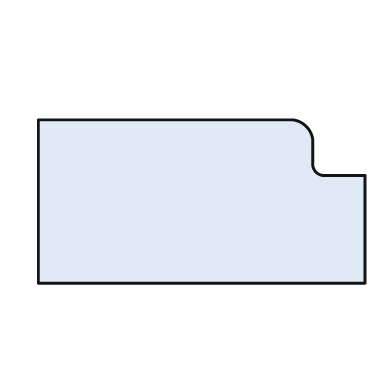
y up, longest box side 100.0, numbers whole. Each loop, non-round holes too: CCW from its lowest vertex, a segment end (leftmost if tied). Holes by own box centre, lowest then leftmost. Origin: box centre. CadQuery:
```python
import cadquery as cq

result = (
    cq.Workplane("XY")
    .moveTo(-50.0, -25.0)
    .lineTo(50.0, -25.0)
    .lineTo(50.0, 8.0)
    .lineTo(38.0, 8.0)
    .threePointArc((35.0, 9.0), (34.0, 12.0))
    .lineTo(34.0, 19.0)
    .threePointArc((32.0, 23.0), (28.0, 25.0))
    .lineTo(-50.0, 25.0)
    .close()
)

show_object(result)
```